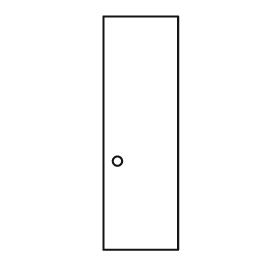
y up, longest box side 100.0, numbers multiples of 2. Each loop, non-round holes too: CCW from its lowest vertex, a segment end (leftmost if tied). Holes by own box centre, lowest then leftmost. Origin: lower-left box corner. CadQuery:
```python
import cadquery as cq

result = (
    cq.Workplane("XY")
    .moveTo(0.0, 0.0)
    .lineTo(32.0, 0.0)
    .lineTo(32.0, 100.0)
    .lineTo(0.0, 100.0)
    .close()
    .moveTo(6.0, 38.0)
    .circle(2.0)
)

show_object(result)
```